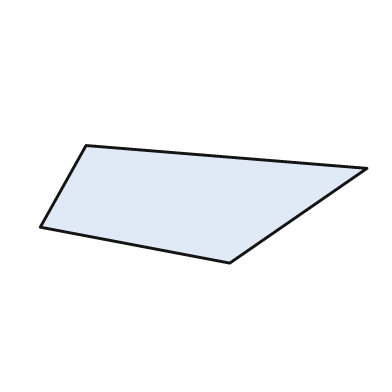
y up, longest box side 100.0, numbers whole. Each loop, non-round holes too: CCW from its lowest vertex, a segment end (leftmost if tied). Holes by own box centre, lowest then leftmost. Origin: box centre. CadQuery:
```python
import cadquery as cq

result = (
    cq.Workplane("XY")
    .moveTo(8.0, -18.0)
    .lineTo(50.0, 11.0)
    .lineTo(-36.0, 18.0)
    .lineTo(-50.0, -7.0)
    .close()
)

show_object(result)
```